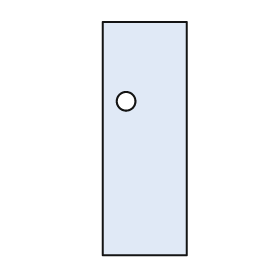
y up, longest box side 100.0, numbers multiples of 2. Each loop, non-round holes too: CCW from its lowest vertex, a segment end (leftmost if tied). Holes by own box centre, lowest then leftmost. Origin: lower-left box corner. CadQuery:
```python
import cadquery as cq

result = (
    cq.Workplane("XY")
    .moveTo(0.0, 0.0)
    .lineTo(36.0, 0.0)
    .lineTo(36.0, 100.0)
    .lineTo(0.0, 100.0)
    .close()
    .moveTo(10.0, 66.0)
    .circle(4.0)
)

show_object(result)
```